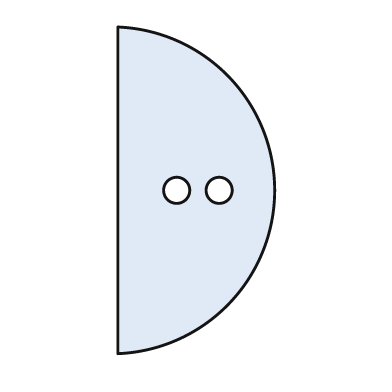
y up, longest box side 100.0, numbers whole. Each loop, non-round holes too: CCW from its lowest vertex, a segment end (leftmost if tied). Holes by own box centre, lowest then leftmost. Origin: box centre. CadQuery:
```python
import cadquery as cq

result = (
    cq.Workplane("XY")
    .moveTo(-24.0, -50.0)
    .threePointArc((24.0, 0.0), (-24.0, 50.0))
    .close()
    .moveTo(-6.0, 0.0)
    .circle(4.0)
    .moveTo(7.0, 0.0)
    .circle(4.0)
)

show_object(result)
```